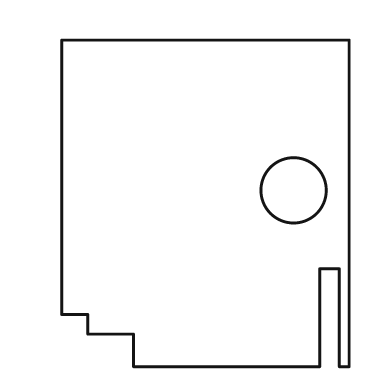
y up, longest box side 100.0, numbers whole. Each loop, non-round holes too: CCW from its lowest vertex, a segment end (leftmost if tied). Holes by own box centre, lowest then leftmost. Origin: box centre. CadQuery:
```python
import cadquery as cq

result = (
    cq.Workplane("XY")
    .moveTo(-22.0, -50.0)
    .lineTo(35.0, -50.0)
    .lineTo(35.0, -20.0)
    .lineTo(41.0, -20.0)
    .lineTo(41.0, -50.0)
    .lineTo(44.0, -50.0)
    .lineTo(44.0, 50.0)
    .lineTo(-44.0, 50.0)
    .lineTo(-44.0, -34.0)
    .lineTo(-36.0, -34.0)
    .lineTo(-36.0, -40.0)
    .lineTo(-22.0, -40.0)
    .close()
    .moveTo(27.0, 4.0)
    .circle(10.0)
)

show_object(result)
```